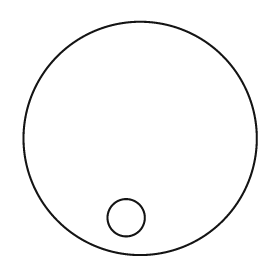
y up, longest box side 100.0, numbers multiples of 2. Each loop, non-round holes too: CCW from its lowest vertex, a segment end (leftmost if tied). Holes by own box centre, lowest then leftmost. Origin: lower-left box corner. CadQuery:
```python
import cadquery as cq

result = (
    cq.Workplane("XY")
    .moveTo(50.0, 50.0)
    .circle(50.0)
    .moveTo(44.0, 16.0)
    .circle(8.0)
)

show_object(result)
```